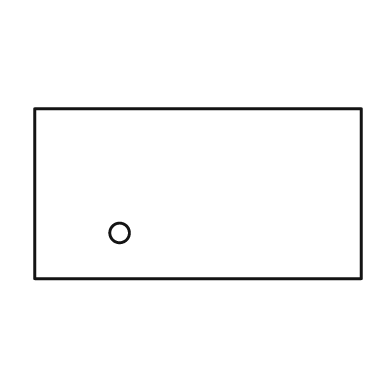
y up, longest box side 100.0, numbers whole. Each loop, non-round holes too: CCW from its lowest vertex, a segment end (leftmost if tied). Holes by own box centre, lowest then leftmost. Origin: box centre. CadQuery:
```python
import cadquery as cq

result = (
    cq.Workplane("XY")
    .moveTo(-50.0, -26.0)
    .lineTo(50.0, -26.0)
    .lineTo(50.0, 26.0)
    .lineTo(-50.0, 26.0)
    .close()
    .moveTo(-24.0, -12.0)
    .circle(3.0)
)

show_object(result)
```